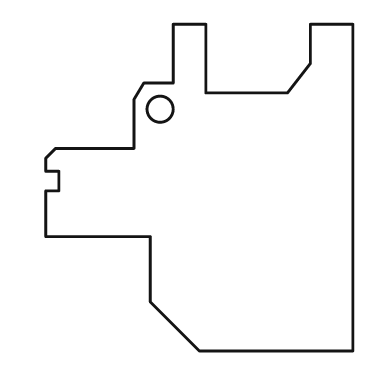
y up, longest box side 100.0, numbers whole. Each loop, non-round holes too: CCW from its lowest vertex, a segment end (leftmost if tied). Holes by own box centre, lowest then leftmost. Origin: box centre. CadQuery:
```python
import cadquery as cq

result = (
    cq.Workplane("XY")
    .moveTo(0.0, -50.0)
    .lineTo(47.0, -50.0)
    .lineTo(47.0, 50.0)
    .lineTo(34.0, 50.0)
    .lineTo(34.0, 38.0)
    .lineTo(27.0, 29.0)
    .lineTo(2.0, 29.0)
    .lineTo(2.0, 50.0)
    .lineTo(-8.0, 50.0)
    .lineTo(-8.0, 32.0)
    .lineTo(-17.0, 32.0)
    .lineTo(-20.0, 27.0)
    .lineTo(-20.0, 12.0)
    .lineTo(-44.0, 12.0)
    .lineTo(-47.0, 9.0)
    .lineTo(-47.0, 5.0)
    .lineTo(-43.0, 5.0)
    .lineTo(-43.0, -1.0)
    .lineTo(-47.0, -1.0)
    .lineTo(-47.0, -15.0)
    .lineTo(-15.0, -15.0)
    .lineTo(-15.0, -35.0)
    .close()
    .moveTo(-12.0, 24.0)
    .circle(4.0)
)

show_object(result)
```